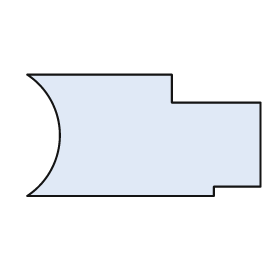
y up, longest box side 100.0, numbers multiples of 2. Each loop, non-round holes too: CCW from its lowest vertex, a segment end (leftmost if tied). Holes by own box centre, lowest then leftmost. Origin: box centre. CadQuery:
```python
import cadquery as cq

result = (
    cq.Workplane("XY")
    .moveTo(-50.0, -26.0)
    .lineTo(30.0, -26.0)
    .lineTo(30.0, -22.0)
    .lineTo(50.0, -22.0)
    .lineTo(50.0, 14.0)
    .lineTo(12.0, 14.0)
    .lineTo(12.0, 26.0)
    .lineTo(-50.0, 26.0)
    .threePointArc((-36.0, 0.0), (-50.0, -26.0))
    .close()
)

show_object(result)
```